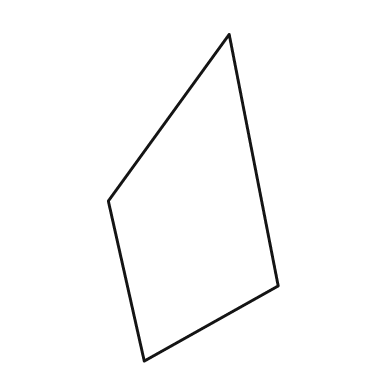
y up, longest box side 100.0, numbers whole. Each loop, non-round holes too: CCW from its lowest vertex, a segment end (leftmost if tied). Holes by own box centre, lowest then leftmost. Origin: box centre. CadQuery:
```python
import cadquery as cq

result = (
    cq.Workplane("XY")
    .moveTo(-15.0, -50.0)
    .lineTo(26.0, -27.0)
    .lineTo(11.0, 50.0)
    .lineTo(-26.0, -1.0)
    .close()
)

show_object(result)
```